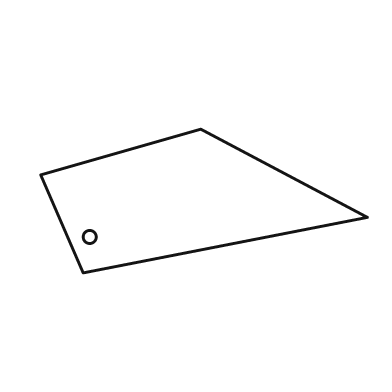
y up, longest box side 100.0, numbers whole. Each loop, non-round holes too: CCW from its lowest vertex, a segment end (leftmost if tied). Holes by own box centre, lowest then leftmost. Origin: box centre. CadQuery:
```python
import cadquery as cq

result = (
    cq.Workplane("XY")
    .moveTo(-37.0, -22.0)
    .lineTo(50.0, -5.0)
    .lineTo(-1.0, 22.0)
    .lineTo(-50.0, 8.0)
    .close()
    .moveTo(-35.0, -11.0)
    .circle(2.0)
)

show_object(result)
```